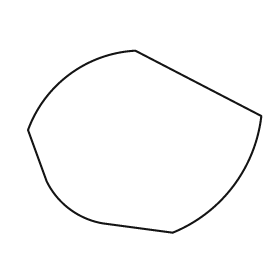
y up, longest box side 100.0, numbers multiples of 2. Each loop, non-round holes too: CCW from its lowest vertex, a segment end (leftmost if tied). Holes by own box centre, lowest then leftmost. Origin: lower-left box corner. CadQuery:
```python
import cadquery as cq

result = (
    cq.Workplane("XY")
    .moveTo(62.0, 0.0)
    .threePointArc((88.0, 20.0), (100.0, 50.0))
    .lineTo(46.0, 78.0)
    .threePointArc((18.0, 68.0), (0.0, 44.0))
    .lineTo(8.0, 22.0)
    .threePointArc((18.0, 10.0), (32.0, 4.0))
    .close()
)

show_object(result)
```